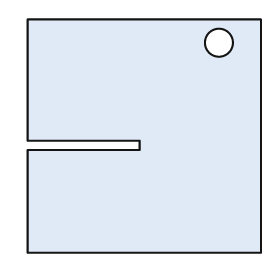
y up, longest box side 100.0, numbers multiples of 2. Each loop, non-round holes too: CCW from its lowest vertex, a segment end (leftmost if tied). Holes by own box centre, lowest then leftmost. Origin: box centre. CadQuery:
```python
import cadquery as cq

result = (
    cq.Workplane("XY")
    .moveTo(-50.0, -50.0)
    .lineTo(50.0, -50.0)
    .lineTo(50.0, 50.0)
    .lineTo(-50.0, 50.0)
    .lineTo(-50.0, -2.0)
    .lineTo(-2.0, -2.0)
    .lineTo(-2.0, -6.0)
    .lineTo(-50.0, -6.0)
    .close()
    .moveTo(32.0, 40.0)
    .circle(6.0)
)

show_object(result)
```